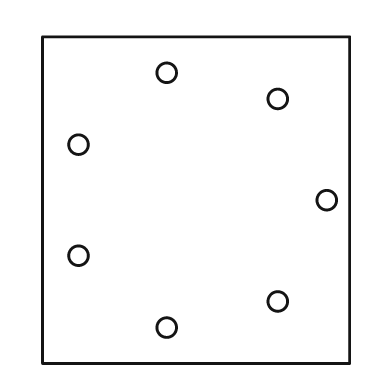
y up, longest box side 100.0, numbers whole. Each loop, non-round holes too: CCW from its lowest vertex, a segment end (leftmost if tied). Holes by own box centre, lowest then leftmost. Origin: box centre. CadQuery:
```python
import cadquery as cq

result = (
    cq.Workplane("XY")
    .moveTo(-47.0, -50.0)
    .lineTo(47.0, -50.0)
    .lineTo(47.0, 50.0)
    .lineTo(-47.0, 50.0)
    .close()
    .moveTo(-9.0, -39.0)
    .circle(3.0)
    .moveTo(25.0, -31.0)
    .circle(3.0)
    .moveTo(-36.0, -17.0)
    .circle(3.0)
    .moveTo(40.0, 0.0)
    .circle(3.0)
    .moveTo(-36.0, 17.0)
    .circle(3.0)
    .moveTo(25.0, 31.0)
    .circle(3.0)
    .moveTo(-9.0, 39.0)
    .circle(3.0)
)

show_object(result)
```